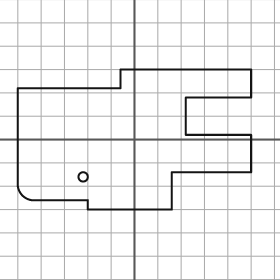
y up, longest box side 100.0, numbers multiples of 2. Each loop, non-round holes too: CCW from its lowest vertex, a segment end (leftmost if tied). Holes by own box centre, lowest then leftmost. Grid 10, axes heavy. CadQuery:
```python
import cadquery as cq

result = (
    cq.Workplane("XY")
    .moveTo(-20.0, -30.0)
    .lineTo(16.0, -30.0)
    .lineTo(16.0, -14.0)
    .lineTo(50.0, -14.0)
    .lineTo(50.0, 2.0)
    .lineTo(22.0, 2.0)
    .lineTo(22.0, 18.0)
    .lineTo(50.0, 18.0)
    .lineTo(50.0, 30.0)
    .lineTo(-6.0, 30.0)
    .lineTo(-6.0, 22.0)
    .lineTo(-50.0, 22.0)
    .lineTo(-50.0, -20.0)
    .threePointArc((-48.0, -24.0), (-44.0, -26.0))
    .lineTo(-20.0, -26.0)
    .close()
    .moveTo(-22.0, -16.0)
    .circle(2.0)
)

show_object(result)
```